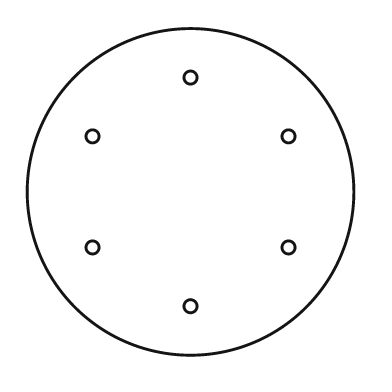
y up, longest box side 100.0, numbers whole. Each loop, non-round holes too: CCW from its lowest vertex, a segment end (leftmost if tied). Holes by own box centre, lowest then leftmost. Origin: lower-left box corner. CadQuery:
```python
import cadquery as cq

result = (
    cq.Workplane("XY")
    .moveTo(50.0, 50.0)
    .circle(50.0)
    .moveTo(50.0, 15.0)
    .circle(2.0)
    .moveTo(20.0, 33.0)
    .circle(2.0)
    .moveTo(80.0, 33.0)
    .circle(2.0)
    .moveTo(20.0, 67.0)
    .circle(2.0)
    .moveTo(80.0, 67.0)
    .circle(2.0)
    .moveTo(50.0, 85.0)
    .circle(2.0)
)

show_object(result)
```